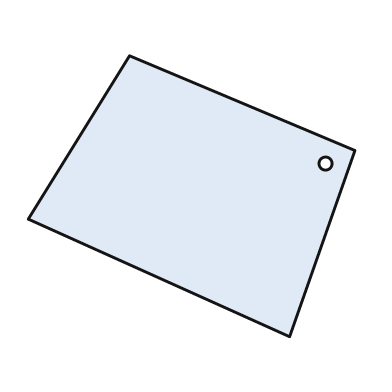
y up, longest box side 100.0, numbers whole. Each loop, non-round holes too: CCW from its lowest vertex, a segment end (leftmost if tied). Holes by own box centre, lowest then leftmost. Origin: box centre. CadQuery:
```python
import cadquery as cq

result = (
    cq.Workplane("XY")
    .moveTo(30.0, -43.0)
    .lineTo(50.0, 14.0)
    .lineTo(-19.0, 43.0)
    .lineTo(-50.0, -7.0)
    .close()
    .moveTo(41.0, 10.0)
    .circle(2.0)
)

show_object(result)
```